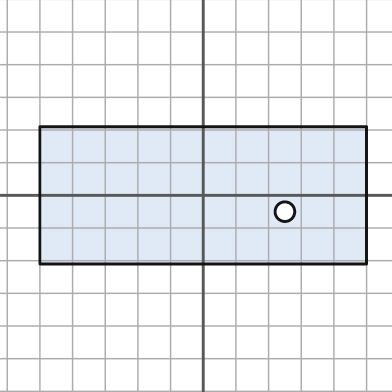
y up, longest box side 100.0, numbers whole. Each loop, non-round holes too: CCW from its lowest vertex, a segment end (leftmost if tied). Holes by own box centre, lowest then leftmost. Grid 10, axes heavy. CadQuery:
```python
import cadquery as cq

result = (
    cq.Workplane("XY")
    .moveTo(-50.0, -21.0)
    .lineTo(50.0, -21.0)
    .lineTo(50.0, 21.0)
    .lineTo(-50.0, 21.0)
    .close()
    .moveTo(25.0, -5.0)
    .circle(3.0)
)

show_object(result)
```